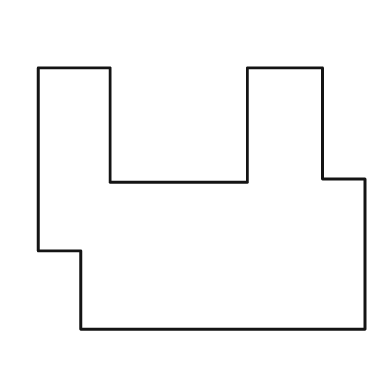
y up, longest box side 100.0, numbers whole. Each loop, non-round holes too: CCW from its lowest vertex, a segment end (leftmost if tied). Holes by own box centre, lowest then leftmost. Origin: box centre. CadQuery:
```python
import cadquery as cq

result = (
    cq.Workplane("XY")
    .moveTo(-37.0, -40.0)
    .lineTo(50.0, -40.0)
    .lineTo(50.0, 6.0)
    .lineTo(37.0, 6.0)
    .lineTo(37.0, 40.0)
    .lineTo(14.0, 40.0)
    .lineTo(14.0, 5.0)
    .lineTo(-28.0, 5.0)
    .lineTo(-28.0, 40.0)
    .lineTo(-50.0, 40.0)
    .lineTo(-50.0, -16.0)
    .lineTo(-37.0, -16.0)
    .close()
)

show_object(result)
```